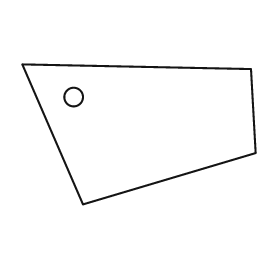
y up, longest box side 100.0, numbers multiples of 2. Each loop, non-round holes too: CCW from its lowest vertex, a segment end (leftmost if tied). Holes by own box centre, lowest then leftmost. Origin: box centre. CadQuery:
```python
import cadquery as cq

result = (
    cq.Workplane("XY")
    .moveTo(-24.0, -30.0)
    .lineTo(50.0, -8.0)
    .lineTo(48.0, 28.0)
    .lineTo(-50.0, 30.0)
    .close()
    .moveTo(-28.0, 16.0)
    .circle(4.0)
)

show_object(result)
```